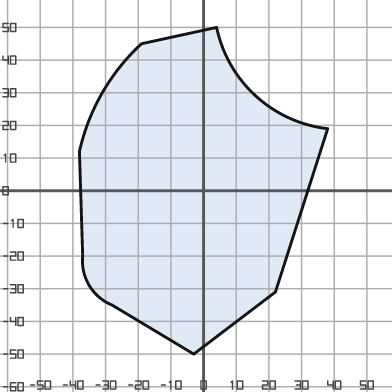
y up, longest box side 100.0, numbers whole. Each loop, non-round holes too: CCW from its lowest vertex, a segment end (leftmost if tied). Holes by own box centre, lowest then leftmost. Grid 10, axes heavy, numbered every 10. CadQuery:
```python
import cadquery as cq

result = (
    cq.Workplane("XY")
    .moveTo(-3.0, -50.0)
    .lineTo(22.0, -31.0)
    .lineTo(38.0, 19.0)
    .threePointArc((16.0, 29.0), (4.0, 50.0))
    .lineTo(-19.0, 45.0)
    .threePointArc((-31.0, 30.0), (-38.0, 12.0))
    .lineTo(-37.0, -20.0)
    .threePointArc((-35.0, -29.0), (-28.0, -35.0))
    .close()
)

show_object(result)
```